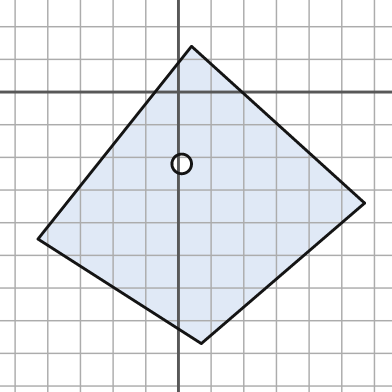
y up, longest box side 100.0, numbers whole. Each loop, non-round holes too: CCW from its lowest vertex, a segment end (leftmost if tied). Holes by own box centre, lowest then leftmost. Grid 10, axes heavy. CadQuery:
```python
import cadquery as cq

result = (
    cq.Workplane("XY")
    .moveTo(7.0, -77.0)
    .lineTo(57.0, -34.0)
    .lineTo(4.0, 14.0)
    .lineTo(-43.0, -45.0)
    .close()
    .moveTo(1.0, -22.0)
    .circle(3.0)
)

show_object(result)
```